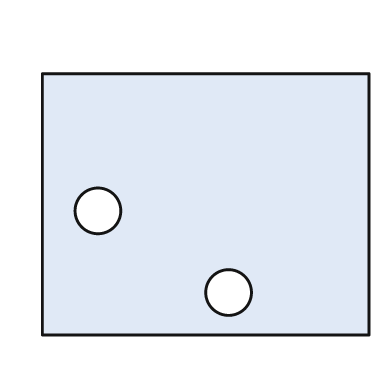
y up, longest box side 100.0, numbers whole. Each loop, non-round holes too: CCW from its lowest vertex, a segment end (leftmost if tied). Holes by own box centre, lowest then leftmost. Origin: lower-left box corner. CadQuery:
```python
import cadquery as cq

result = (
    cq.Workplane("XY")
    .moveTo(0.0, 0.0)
    .lineTo(100.0, 0.0)
    .lineTo(100.0, 80.0)
    .lineTo(0.0, 80.0)
    .close()
    .moveTo(57.0, 13.0)
    .circle(7.0)
    .moveTo(17.0, 38.0)
    .circle(7.0)
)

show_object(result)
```